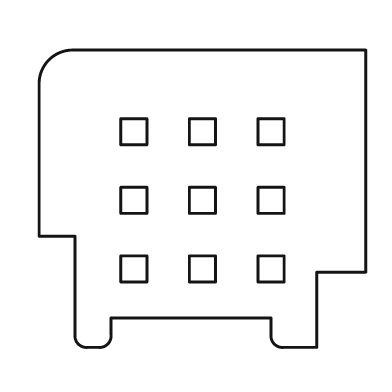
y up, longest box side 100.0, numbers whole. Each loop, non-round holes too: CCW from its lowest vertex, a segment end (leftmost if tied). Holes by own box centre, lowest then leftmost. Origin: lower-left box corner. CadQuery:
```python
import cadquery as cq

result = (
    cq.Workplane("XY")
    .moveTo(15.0, 0.0)
    .lineTo(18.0, 0.0)
    .threePointArc((21.0, 1.0), (22.0, 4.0))
    .lineTo(22.0, 9.0)
    .lineTo(71.0, 9.0)
    .lineTo(71.0, 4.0)
    .threePointArc((72.0, 1.0), (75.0, 0.0))
    .lineTo(85.0, 0.0)
    .lineTo(85.0, 23.0)
    .lineTo(100.0, 23.0)
    .lineTo(100.0, 91.0)
    .lineTo(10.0, 91.0)
    .threePointArc((3.0, 88.0), (0.0, 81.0))
    .lineTo(0.0, 34.0)
    .lineTo(11.0, 34.0)
    .lineTo(11.0, 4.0)
    .threePointArc((12.0, 1.0), (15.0, 0.0))
    .close()
    .moveTo(25.0, 20.0)
    .lineTo(33.0, 20.0)
    .lineTo(33.0, 28.0)
    .lineTo(25.0, 28.0)
    .close()
    .moveTo(46.0, 20.0)
    .lineTo(54.0, 20.0)
    .lineTo(54.0, 28.0)
    .lineTo(46.0, 28.0)
    .close()
    .moveTo(67.0, 20.0)
    .lineTo(75.0, 20.0)
    .lineTo(75.0, 28.0)
    .lineTo(67.0, 28.0)
    .close()
    .moveTo(25.0, 41.0)
    .lineTo(33.0, 41.0)
    .lineTo(33.0, 49.0)
    .lineTo(25.0, 49.0)
    .close()
    .moveTo(46.0, 41.0)
    .lineTo(54.0, 41.0)
    .lineTo(54.0, 49.0)
    .lineTo(46.0, 49.0)
    .close()
    .moveTo(67.0, 41.0)
    .lineTo(75.0, 41.0)
    .lineTo(75.0, 49.0)
    .lineTo(67.0, 49.0)
    .close()
    .moveTo(25.0, 62.0)
    .lineTo(33.0, 62.0)
    .lineTo(33.0, 70.0)
    .lineTo(25.0, 70.0)
    .close()
    .moveTo(46.0, 62.0)
    .lineTo(54.0, 62.0)
    .lineTo(54.0, 70.0)
    .lineTo(46.0, 70.0)
    .close()
    .moveTo(67.0, 62.0)
    .lineTo(75.0, 62.0)
    .lineTo(75.0, 70.0)
    .lineTo(67.0, 70.0)
    .close()
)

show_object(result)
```